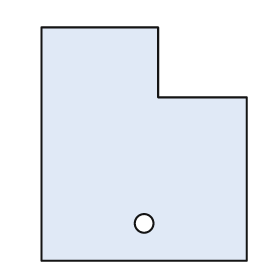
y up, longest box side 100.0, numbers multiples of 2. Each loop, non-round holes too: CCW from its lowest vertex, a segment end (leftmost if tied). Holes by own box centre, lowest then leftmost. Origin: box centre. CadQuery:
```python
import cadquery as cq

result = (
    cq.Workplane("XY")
    .moveTo(-44.0, -50.0)
    .lineTo(44.0, -50.0)
    .lineTo(44.0, 20.0)
    .lineTo(6.0, 20.0)
    .lineTo(6.0, 50.0)
    .lineTo(-44.0, 50.0)
    .close()
    .moveTo(0.0, -34.0)
    .circle(4.0)
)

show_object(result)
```